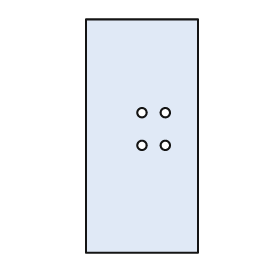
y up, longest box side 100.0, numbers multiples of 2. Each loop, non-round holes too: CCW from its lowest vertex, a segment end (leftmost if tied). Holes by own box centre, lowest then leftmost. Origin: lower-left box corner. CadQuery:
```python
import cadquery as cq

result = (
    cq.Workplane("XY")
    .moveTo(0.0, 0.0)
    .lineTo(48.0, 0.0)
    .lineTo(48.0, 100.0)
    .lineTo(0.0, 100.0)
    .close()
    .moveTo(24.0, 46.0)
    .circle(2.0)
    .moveTo(34.0, 46.0)
    .circle(2.0)
    .moveTo(24.0, 60.0)
    .circle(2.0)
    .moveTo(34.0, 60.0)
    .circle(2.0)
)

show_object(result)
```